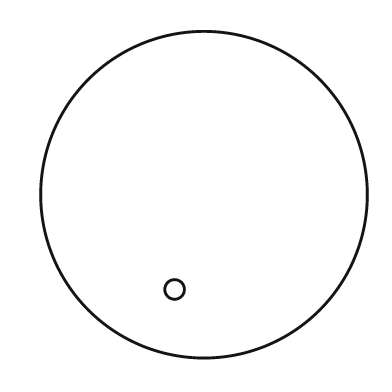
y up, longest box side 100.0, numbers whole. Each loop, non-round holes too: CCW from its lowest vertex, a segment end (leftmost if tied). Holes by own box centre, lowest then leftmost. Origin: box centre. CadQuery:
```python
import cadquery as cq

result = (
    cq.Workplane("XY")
    .moveTo(0.0, 0.0)
    .circle(50.0)
    .moveTo(-9.0, -29.0)
    .circle(3.0)
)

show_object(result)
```